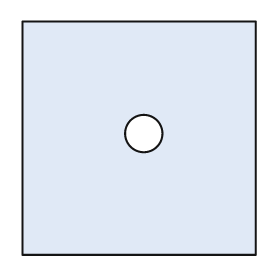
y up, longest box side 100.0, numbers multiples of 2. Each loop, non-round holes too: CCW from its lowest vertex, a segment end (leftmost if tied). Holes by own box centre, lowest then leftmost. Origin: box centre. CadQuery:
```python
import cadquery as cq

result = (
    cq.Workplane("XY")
    .moveTo(-50.0, -50.0)
    .lineTo(50.0, -50.0)
    .lineTo(50.0, 50.0)
    .lineTo(-50.0, 50.0)
    .close()
    .moveTo(2.0, 2.0)
    .circle(8.0)
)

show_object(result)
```